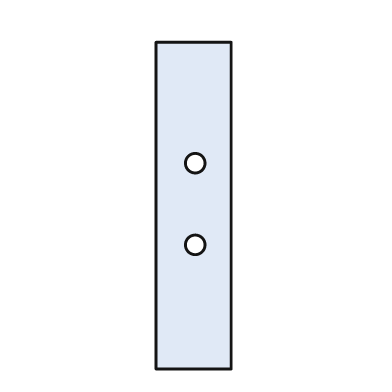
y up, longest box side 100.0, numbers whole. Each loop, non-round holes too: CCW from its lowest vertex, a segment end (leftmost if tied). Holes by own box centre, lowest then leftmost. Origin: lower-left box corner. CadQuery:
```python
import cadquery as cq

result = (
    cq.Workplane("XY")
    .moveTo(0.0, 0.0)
    .lineTo(23.0, 0.0)
    .lineTo(23.0, 100.0)
    .lineTo(0.0, 100.0)
    .close()
    .moveTo(12.0, 38.0)
    .circle(3.0)
    .moveTo(12.0, 63.0)
    .circle(3.0)
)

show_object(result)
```